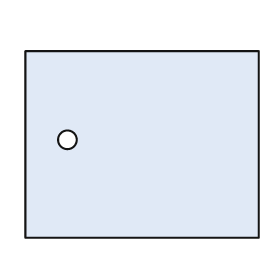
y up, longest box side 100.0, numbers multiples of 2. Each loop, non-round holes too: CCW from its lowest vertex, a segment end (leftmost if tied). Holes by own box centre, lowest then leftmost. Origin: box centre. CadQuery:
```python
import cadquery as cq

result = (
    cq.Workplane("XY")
    .moveTo(-50.0, -40.0)
    .lineTo(50.0, -40.0)
    .lineTo(50.0, 40.0)
    .lineTo(-50.0, 40.0)
    .close()
    .moveTo(-32.0, 2.0)
    .circle(4.0)
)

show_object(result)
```